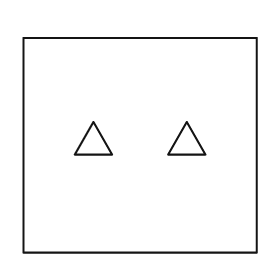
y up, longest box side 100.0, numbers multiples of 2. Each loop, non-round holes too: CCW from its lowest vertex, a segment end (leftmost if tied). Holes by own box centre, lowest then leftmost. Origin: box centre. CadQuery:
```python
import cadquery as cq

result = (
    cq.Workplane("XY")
    .moveTo(-50.0, -46.0)
    .lineTo(50.0, -46.0)
    .lineTo(50.0, 46.0)
    .lineTo(-50.0, 46.0)
    .close()
    .moveTo(-28.0, -4.0)
    .lineTo(-12.0, -4.0)
    .lineTo(-20.0, 10.0)
    .close()
    .moveTo(12.0, -4.0)
    .lineTo(28.0, -4.0)
    .lineTo(20.0, 10.0)
    .close()
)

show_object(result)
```